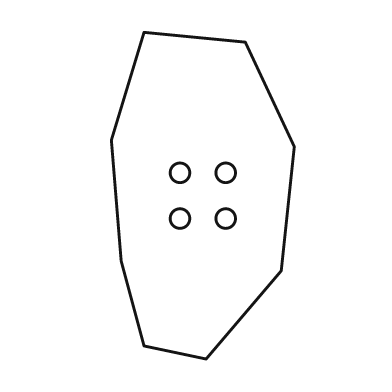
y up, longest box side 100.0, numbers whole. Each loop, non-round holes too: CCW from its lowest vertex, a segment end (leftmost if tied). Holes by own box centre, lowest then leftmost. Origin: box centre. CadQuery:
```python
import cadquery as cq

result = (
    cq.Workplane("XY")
    .moveTo(1.0, -50.0)
    .lineTo(24.0, -23.0)
    .lineTo(28.0, 15.0)
    .lineTo(13.0, 47.0)
    .lineTo(-18.0, 50.0)
    .lineTo(-28.0, 17.0)
    .lineTo(-25.0, -20.0)
    .lineTo(-18.0, -46.0)
    .close()
    .moveTo(-7.0, -7.0)
    .circle(3.0)
    .moveTo(7.0, -7.0)
    .circle(3.0)
    .moveTo(-7.0, 7.0)
    .circle(3.0)
    .moveTo(7.0, 7.0)
    .circle(3.0)
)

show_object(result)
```